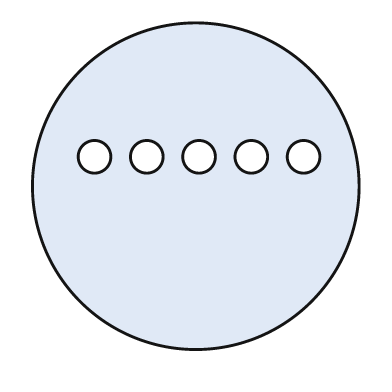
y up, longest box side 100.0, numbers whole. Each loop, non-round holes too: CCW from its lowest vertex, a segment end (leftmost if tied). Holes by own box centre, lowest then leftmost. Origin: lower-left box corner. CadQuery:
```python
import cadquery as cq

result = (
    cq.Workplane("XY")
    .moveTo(50.0, 50.0)
    .circle(50.0)
    .moveTo(19.0, 59.0)
    .circle(5.0)
    .moveTo(35.0, 59.0)
    .circle(5.0)
    .moveTo(51.0, 59.0)
    .circle(5.0)
    .moveTo(67.0, 59.0)
    .circle(5.0)
    .moveTo(83.0, 59.0)
    .circle(5.0)
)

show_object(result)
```